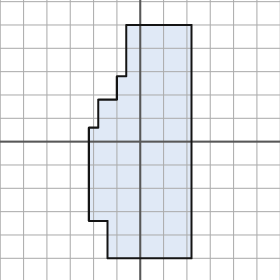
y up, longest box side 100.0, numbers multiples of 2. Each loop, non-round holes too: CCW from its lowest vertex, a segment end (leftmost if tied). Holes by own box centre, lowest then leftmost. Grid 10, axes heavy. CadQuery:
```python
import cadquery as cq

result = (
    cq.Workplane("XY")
    .moveTo(-14.0, -50.0)
    .lineTo(22.0, -50.0)
    .lineTo(22.0, 50.0)
    .lineTo(-6.0, 50.0)
    .lineTo(-6.0, 28.0)
    .lineTo(-10.0, 28.0)
    .lineTo(-10.0, 18.0)
    .lineTo(-18.0, 18.0)
    .lineTo(-18.0, 6.0)
    .lineTo(-22.0, 6.0)
    .lineTo(-22.0, -34.0)
    .lineTo(-14.0, -34.0)
    .close()
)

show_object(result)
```